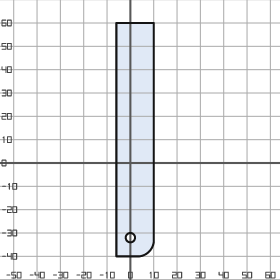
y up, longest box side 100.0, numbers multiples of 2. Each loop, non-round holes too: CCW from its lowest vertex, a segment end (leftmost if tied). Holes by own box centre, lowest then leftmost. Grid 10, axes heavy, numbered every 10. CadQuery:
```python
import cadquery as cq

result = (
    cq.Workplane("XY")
    .moveTo(-6.0, -40.0)
    .lineTo(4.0, -40.0)
    .threePointArc((8.0, -38.0), (10.0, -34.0))
    .lineTo(10.0, 60.0)
    .lineTo(-6.0, 60.0)
    .close()
    .moveTo(0.0, -32.0)
    .circle(2.0)
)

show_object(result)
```